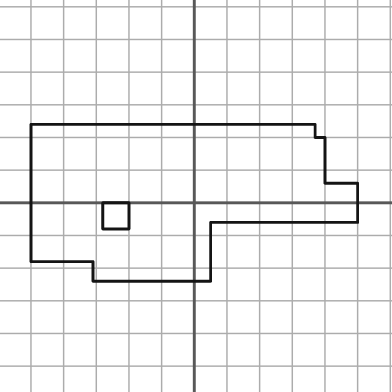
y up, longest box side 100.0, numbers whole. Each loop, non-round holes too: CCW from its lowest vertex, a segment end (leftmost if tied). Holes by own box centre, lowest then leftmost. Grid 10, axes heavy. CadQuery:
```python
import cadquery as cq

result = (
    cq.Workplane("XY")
    .moveTo(-31.0, -24.0)
    .lineTo(5.0, -24.0)
    .lineTo(5.0, -6.0)
    .lineTo(50.0, -6.0)
    .lineTo(50.0, 6.0)
    .lineTo(40.0, 6.0)
    .lineTo(40.0, 20.0)
    .lineTo(37.0, 20.0)
    .lineTo(37.0, 24.0)
    .lineTo(-50.0, 24.0)
    .lineTo(-50.0, -18.0)
    .lineTo(-31.0, -18.0)
    .close()
    .moveTo(-28.0, -8.0)
    .lineTo(-20.0, -8.0)
    .lineTo(-20.0, 0.0)
    .lineTo(-28.0, 0.0)
    .close()
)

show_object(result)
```